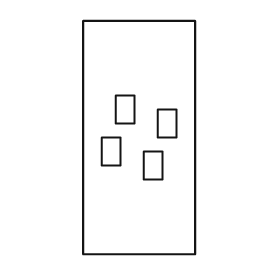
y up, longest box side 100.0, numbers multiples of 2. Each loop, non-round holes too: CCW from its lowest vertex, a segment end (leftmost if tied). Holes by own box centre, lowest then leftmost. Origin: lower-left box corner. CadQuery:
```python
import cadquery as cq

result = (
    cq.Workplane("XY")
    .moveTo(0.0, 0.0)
    .lineTo(48.0, 0.0)
    .lineTo(48.0, 100.0)
    .lineTo(0.0, 100.0)
    .close()
    .moveTo(26.0, 32.0)
    .lineTo(34.0, 32.0)
    .lineTo(34.0, 44.0)
    .lineTo(26.0, 44.0)
    .close()
    .moveTo(8.0, 38.0)
    .lineTo(16.0, 38.0)
    .lineTo(16.0, 50.0)
    .lineTo(8.0, 50.0)
    .close()
    .moveTo(32.0, 50.0)
    .lineTo(40.0, 50.0)
    .lineTo(40.0, 62.0)
    .lineTo(32.0, 62.0)
    .close()
    .moveTo(14.0, 56.0)
    .lineTo(22.0, 56.0)
    .lineTo(22.0, 68.0)
    .lineTo(14.0, 68.0)
    .close()
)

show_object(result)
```